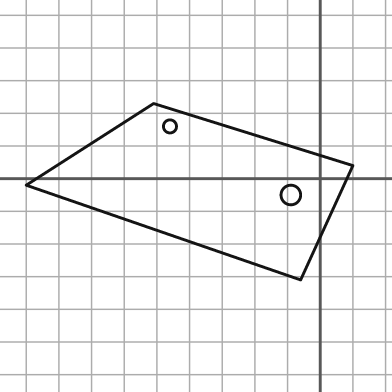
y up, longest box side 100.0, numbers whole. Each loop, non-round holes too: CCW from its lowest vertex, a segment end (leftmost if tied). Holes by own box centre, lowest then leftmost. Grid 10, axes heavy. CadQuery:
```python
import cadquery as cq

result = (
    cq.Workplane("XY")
    .moveTo(-6.0, -31.0)
    .lineTo(10.0, 4.0)
    .lineTo(-51.0, 23.0)
    .lineTo(-90.0, -2.0)
    .close()
    .moveTo(-9.0, -5.0)
    .circle(3.0)
    .moveTo(-46.0, 16.0)
    .circle(2.0)
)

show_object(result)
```